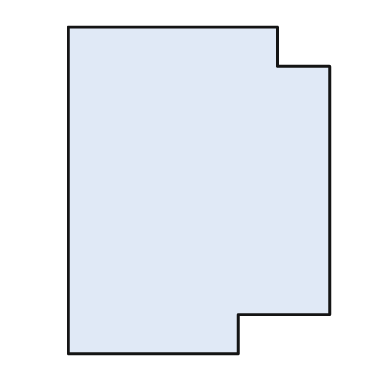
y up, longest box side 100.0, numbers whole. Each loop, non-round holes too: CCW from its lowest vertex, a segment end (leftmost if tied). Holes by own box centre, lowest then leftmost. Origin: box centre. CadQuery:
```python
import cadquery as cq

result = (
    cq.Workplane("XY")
    .moveTo(-40.0, -50.0)
    .lineTo(12.0, -50.0)
    .lineTo(12.0, -38.0)
    .lineTo(40.0, -38.0)
    .lineTo(40.0, 38.0)
    .lineTo(24.0, 38.0)
    .lineTo(24.0, 50.0)
    .lineTo(-40.0, 50.0)
    .close()
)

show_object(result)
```